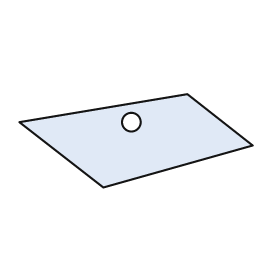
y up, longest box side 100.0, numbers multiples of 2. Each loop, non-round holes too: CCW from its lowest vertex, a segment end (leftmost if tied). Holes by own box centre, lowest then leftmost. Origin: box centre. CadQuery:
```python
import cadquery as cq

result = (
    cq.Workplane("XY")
    .moveTo(-14.0, -20.0)
    .lineTo(50.0, -2.0)
    .lineTo(22.0, 20.0)
    .lineTo(-50.0, 8.0)
    .close()
    .moveTo(-2.0, 8.0)
    .circle(4.0)
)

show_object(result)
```